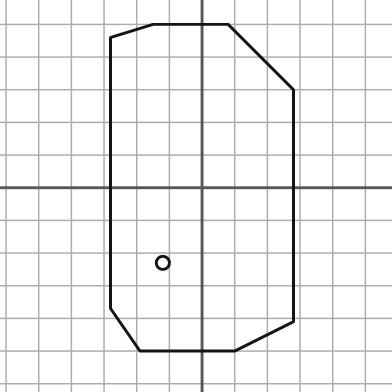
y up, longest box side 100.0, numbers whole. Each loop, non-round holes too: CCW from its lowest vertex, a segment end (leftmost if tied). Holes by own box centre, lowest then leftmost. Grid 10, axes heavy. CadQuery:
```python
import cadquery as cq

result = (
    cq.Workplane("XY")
    .moveTo(-19.0, -50.0)
    .lineTo(10.0, -50.0)
    .lineTo(28.0, -41.0)
    .lineTo(28.0, 30.0)
    .lineTo(8.0, 50.0)
    .lineTo(-15.0, 50.0)
    .lineTo(-28.0, 46.0)
    .lineTo(-28.0, -37.0)
    .close()
    .moveTo(-12.0, -23.0)
    .circle(2.0)
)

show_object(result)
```